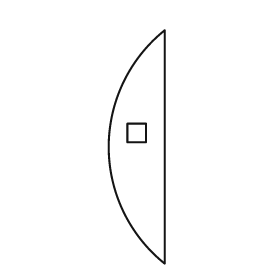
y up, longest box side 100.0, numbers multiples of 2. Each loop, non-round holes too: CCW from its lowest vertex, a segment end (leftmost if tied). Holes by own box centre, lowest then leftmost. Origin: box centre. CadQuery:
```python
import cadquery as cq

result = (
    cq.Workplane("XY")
    .moveTo(12.0, -50.0)
    .lineTo(12.0, 50.0)
    .threePointArc((-12.0, 0.0), (12.0, -50.0))
    .close()
    .moveTo(-4.0, 2.0)
    .lineTo(4.0, 2.0)
    .lineTo(4.0, 10.0)
    .lineTo(-4.0, 10.0)
    .close()
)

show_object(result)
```